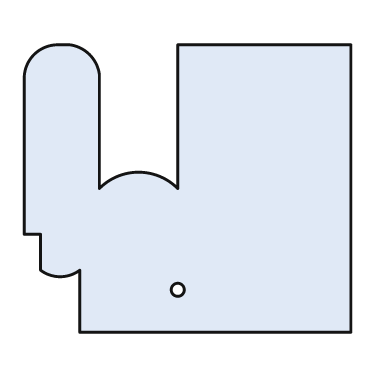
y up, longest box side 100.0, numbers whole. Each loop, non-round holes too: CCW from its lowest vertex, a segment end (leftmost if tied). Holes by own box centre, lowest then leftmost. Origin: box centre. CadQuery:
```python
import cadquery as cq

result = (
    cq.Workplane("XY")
    .moveTo(-33.0, -44.0)
    .lineTo(50.0, -44.0)
    .lineTo(50.0, 44.0)
    .lineTo(-3.0, 44.0)
    .lineTo(-3.0, 0.0)
    .threePointArc((-15.0, 5.0), (-27.0, 0.0))
    .lineTo(-27.0, 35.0)
    .threePointArc((-30.0, 41.0), (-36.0, 44.0))
    .lineTo(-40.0, 44.0)
    .threePointArc((-47.0, 41.0), (-50.0, 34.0))
    .lineTo(-50.0, -14.0)
    .lineTo(-45.0, -14.0)
    .lineTo(-45.0, -25.0)
    .threePointArc((-39.0, -27.0), (-33.0, -25.0))
    .close()
    .moveTo(-3.0, -31.0)
    .circle(2.0)
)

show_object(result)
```